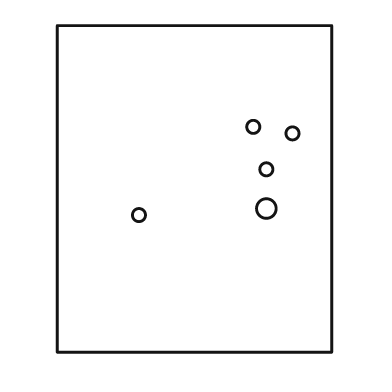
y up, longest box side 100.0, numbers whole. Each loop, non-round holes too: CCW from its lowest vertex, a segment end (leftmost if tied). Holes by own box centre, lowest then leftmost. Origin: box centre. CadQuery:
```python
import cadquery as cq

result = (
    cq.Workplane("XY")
    .moveTo(-42.0, -50.0)
    .lineTo(42.0, -50.0)
    .lineTo(42.0, 50.0)
    .lineTo(-42.0, 50.0)
    .close()
    .moveTo(-17.0, -8.0)
    .circle(2.0)
    .moveTo(22.0, -6.0)
    .circle(3.0)
    .moveTo(22.0, 6.0)
    .circle(2.0)
    .moveTo(30.0, 17.0)
    .circle(2.0)
    .moveTo(18.0, 19.0)
    .circle(2.0)
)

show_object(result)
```